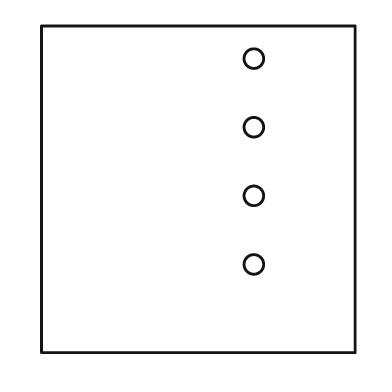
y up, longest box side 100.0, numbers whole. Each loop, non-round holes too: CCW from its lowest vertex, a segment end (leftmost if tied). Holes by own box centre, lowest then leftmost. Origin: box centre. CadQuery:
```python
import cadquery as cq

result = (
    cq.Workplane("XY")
    .moveTo(-48.0, -50.0)
    .lineTo(48.0, -50.0)
    .lineTo(48.0, 50.0)
    .lineTo(-48.0, 50.0)
    .close()
    .moveTo(17.0, -23.0)
    .circle(3.0)
    .moveTo(17.0, -2.0)
    .circle(3.0)
    .moveTo(17.0, 19.0)
    .circle(3.0)
    .moveTo(17.0, 40.0)
    .circle(3.0)
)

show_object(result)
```